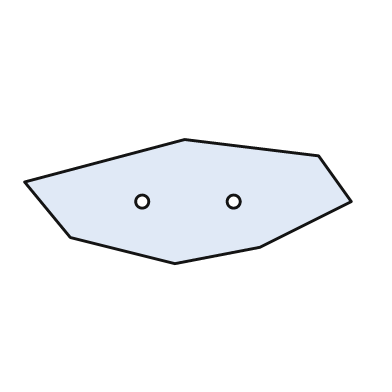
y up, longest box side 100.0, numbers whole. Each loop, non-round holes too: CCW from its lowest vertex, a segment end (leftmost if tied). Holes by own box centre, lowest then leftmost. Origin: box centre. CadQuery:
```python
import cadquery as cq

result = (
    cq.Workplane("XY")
    .moveTo(-4.0, -19.0)
    .lineTo(22.0, -14.0)
    .lineTo(50.0, 0.0)
    .lineTo(40.0, 14.0)
    .lineTo(-1.0, 19.0)
    .lineTo(-50.0, 6.0)
    .lineTo(-36.0, -11.0)
    .close()
    .moveTo(-14.0, 0.0)
    .circle(2.0)
    .moveTo(14.0, 0.0)
    .circle(2.0)
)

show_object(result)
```